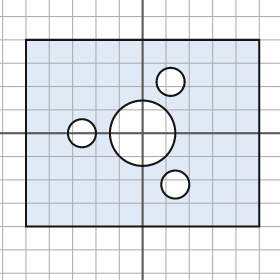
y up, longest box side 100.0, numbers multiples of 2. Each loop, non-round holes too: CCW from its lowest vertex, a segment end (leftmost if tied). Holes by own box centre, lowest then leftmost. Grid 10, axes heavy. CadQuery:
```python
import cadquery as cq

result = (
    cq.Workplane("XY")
    .moveTo(-50.0, -40.0)
    .lineTo(50.0, -40.0)
    .lineTo(50.0, 40.0)
    .lineTo(-50.0, 40.0)
    .close()
    .moveTo(14.0, -22.0)
    .circle(6.0)
    .moveTo(-26.0, 0.0)
    .circle(6.0)
    .moveTo(0.0, 0.0)
    .circle(14.0)
    .moveTo(12.0, 22.0)
    .circle(6.0)
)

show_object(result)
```